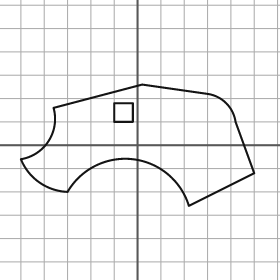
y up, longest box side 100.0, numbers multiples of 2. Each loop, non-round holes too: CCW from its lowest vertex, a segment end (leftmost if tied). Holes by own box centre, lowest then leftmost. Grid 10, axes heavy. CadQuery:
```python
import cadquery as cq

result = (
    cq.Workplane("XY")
    .moveTo(22.0, -26.0)
    .lineTo(50.0, -12.0)
    .lineTo(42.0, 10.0)
    .threePointArc((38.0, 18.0), (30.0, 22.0))
    .lineTo(2.0, 26.0)
    .lineTo(-36.0, 16.0)
    .threePointArc((-38.0, 2.0), (-50.0, -6.0))
    .threePointArc((-42.0, -16.0), (-30.0, -20.0))
    .threePointArc((-2.0, -6.0), (22.0, -26.0))
    .close()
    .moveTo(-10.0, 10.0)
    .lineTo(-2.0, 10.0)
    .lineTo(-2.0, 18.0)
    .lineTo(-10.0, 18.0)
    .close()
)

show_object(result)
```